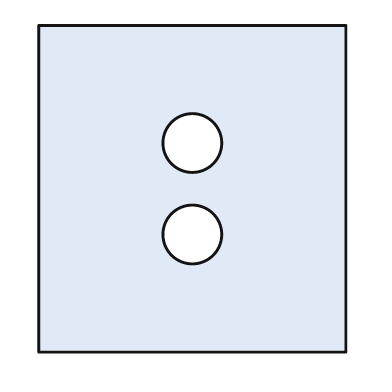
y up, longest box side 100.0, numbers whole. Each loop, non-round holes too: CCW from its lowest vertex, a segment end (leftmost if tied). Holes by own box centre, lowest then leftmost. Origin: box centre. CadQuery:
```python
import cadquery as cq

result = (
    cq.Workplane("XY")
    .moveTo(-47.0, -50.0)
    .lineTo(47.0, -50.0)
    .lineTo(47.0, 50.0)
    .lineTo(-47.0, 50.0)
    .close()
    .moveTo(0.0, -14.0)
    .circle(9.0)
    .moveTo(0.0, 14.0)
    .circle(9.0)
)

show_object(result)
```